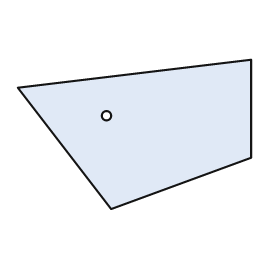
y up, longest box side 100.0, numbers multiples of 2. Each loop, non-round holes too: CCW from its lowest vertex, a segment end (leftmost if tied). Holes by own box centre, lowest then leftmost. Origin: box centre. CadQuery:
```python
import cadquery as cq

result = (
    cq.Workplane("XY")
    .moveTo(-10.0, -32.0)
    .lineTo(50.0, -10.0)
    .lineTo(50.0, 32.0)
    .lineTo(-50.0, 20.0)
    .close()
    .moveTo(-12.0, 8.0)
    .circle(2.0)
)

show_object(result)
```